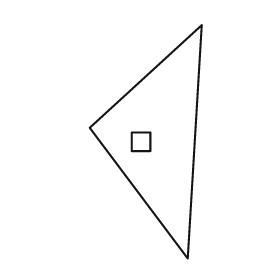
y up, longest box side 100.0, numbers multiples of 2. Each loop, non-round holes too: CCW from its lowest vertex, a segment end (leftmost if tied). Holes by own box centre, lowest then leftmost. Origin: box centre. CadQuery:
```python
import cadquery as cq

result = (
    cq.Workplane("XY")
    .moveTo(18.0, -50.0)
    .lineTo(24.0, 50.0)
    .lineTo(-24.0, 6.0)
    .close()
    .moveTo(-6.0, -4.0)
    .lineTo(2.0, -4.0)
    .lineTo(2.0, 4.0)
    .lineTo(-6.0, 4.0)
    .close()
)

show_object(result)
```